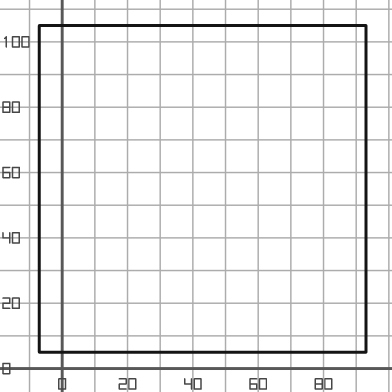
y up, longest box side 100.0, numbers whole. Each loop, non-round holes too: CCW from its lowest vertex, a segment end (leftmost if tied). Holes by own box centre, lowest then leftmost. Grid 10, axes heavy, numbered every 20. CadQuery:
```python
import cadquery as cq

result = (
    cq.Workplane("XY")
    .moveTo(-7.0, 5.0)
    .lineTo(93.0, 5.0)
    .lineTo(93.0, 105.0)
    .lineTo(-7.0, 105.0)
    .close()
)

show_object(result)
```